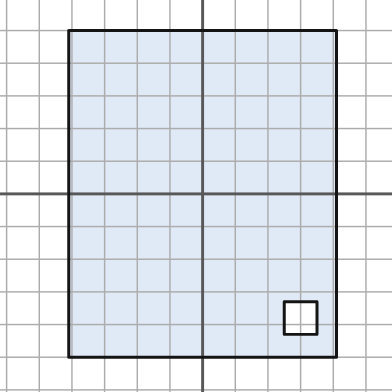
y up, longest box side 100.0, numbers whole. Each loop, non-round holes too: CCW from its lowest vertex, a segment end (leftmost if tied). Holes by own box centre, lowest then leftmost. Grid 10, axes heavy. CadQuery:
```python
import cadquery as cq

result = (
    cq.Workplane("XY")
    .moveTo(-41.0, -50.0)
    .lineTo(41.0, -50.0)
    .lineTo(41.0, 50.0)
    .lineTo(-41.0, 50.0)
    .close()
    .moveTo(25.0, -43.0)
    .lineTo(35.0, -43.0)
    .lineTo(35.0, -33.0)
    .lineTo(25.0, -33.0)
    .close()
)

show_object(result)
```